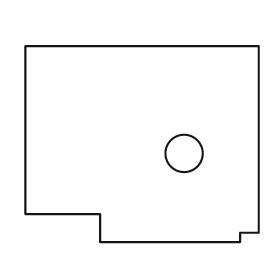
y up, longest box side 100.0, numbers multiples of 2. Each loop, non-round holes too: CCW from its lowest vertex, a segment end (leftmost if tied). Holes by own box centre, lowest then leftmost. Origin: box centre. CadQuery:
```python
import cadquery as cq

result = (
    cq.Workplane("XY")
    .moveTo(-18.0, -42.0)
    .lineTo(42.0, -42.0)
    .lineTo(42.0, -38.0)
    .lineTo(50.0, -38.0)
    .lineTo(50.0, 42.0)
    .lineTo(-50.0, 42.0)
    .lineTo(-50.0, -30.0)
    .lineTo(-18.0, -30.0)
    .close()
    .moveTo(18.0, -4.0)
    .circle(8.0)
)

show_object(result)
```